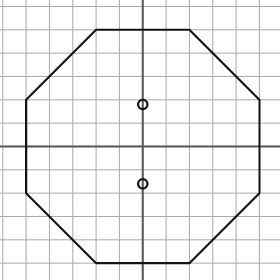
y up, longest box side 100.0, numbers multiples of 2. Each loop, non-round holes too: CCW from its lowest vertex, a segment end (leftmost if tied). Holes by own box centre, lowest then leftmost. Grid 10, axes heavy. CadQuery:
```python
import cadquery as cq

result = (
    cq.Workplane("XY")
    .moveTo(-20.0, -50.0)
    .lineTo(20.0, -50.0)
    .lineTo(50.0, -20.0)
    .lineTo(50.0, 20.0)
    .lineTo(20.0, 50.0)
    .lineTo(-20.0, 50.0)
    .lineTo(-50.0, 20.0)
    .lineTo(-50.0, -20.0)
    .close()
    .moveTo(0.0, -16.0)
    .circle(2.0)
    .moveTo(0.0, 18.0)
    .circle(2.0)
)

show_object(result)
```